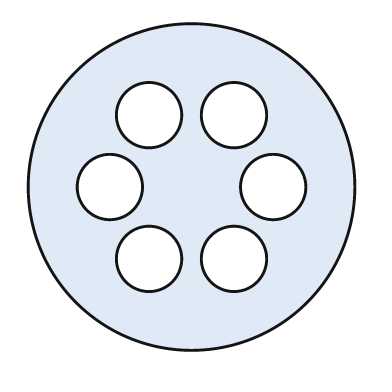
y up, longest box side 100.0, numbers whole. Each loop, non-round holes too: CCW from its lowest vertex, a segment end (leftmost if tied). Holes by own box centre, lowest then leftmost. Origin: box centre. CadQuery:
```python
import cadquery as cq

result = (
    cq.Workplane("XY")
    .moveTo(0.0, 0.0)
    .circle(50.0)
    .moveTo(-13.0, -22.0)
    .circle(10.0)
    .moveTo(13.0, -22.0)
    .circle(10.0)
    .moveTo(-25.0, 0.0)
    .circle(10.0)
    .moveTo(25.0, 0.0)
    .circle(10.0)
    .moveTo(-13.0, 22.0)
    .circle(10.0)
    .moveTo(13.0, 22.0)
    .circle(10.0)
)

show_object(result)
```